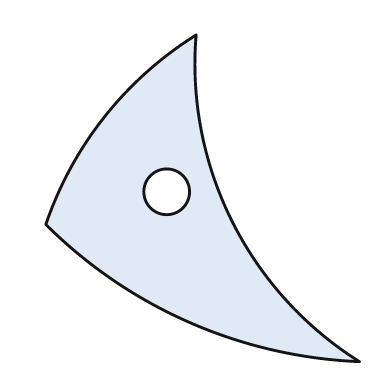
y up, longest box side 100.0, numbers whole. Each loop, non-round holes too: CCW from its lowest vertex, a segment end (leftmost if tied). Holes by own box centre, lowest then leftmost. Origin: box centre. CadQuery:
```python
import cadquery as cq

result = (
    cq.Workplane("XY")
    .moveTo(48.0, -50.0)
    .threePointArc((9.0, -7.0), (-2.0, 50.0))
    .threePointArc((-30.0, 25.0), (-48.0, -8.0))
    .threePointArc((-4.0, -38.0), (48.0, -50.0))
    .close()
    .moveTo(-11.0, 2.0)
    .circle(7.0)
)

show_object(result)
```